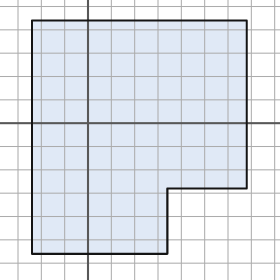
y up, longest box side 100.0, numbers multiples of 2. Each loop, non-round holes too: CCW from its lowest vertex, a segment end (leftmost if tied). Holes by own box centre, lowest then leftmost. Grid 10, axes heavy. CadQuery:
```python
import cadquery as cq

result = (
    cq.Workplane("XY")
    .moveTo(-24.0, -56.0)
    .lineTo(34.0, -56.0)
    .lineTo(34.0, -28.0)
    .lineTo(68.0, -28.0)
    .lineTo(68.0, 44.0)
    .lineTo(-24.0, 44.0)
    .close()
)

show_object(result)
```